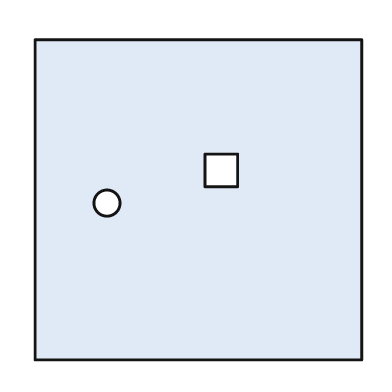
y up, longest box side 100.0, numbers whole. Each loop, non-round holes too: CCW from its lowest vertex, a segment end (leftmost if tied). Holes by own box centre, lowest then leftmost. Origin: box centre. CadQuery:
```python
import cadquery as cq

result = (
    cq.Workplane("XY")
    .moveTo(-50.0, -49.0)
    .lineTo(50.0, -49.0)
    .lineTo(50.0, 49.0)
    .lineTo(-50.0, 49.0)
    .close()
    .moveTo(-28.0, -1.0)
    .circle(4.0)
    .moveTo(2.0, 4.0)
    .lineTo(12.0, 4.0)
    .lineTo(12.0, 14.0)
    .lineTo(2.0, 14.0)
    .close()
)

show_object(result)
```